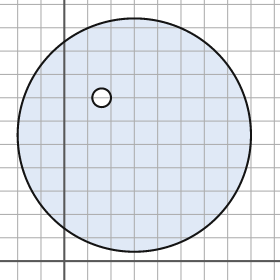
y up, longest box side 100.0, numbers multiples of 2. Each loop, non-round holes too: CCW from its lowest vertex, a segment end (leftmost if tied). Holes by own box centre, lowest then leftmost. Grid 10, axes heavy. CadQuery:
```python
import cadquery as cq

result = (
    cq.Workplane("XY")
    .moveTo(30.0, 54.0)
    .circle(50.0)
    .moveTo(16.0, 70.0)
    .circle(4.0)
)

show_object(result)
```